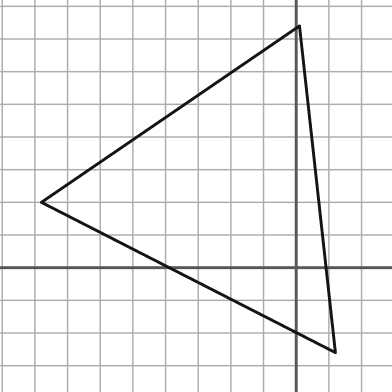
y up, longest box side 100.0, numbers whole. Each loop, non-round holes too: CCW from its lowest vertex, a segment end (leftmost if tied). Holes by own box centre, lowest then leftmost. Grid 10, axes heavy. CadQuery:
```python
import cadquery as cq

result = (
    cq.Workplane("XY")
    .moveTo(12.0, -26.0)
    .lineTo(1.0, 74.0)
    .lineTo(-78.0, 20.0)
    .close()
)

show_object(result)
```